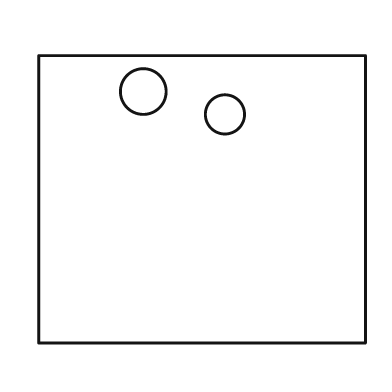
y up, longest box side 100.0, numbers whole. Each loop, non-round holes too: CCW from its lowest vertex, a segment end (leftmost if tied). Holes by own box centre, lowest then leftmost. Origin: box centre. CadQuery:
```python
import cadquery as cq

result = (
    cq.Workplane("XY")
    .moveTo(-50.0, -44.0)
    .lineTo(50.0, -44.0)
    .lineTo(50.0, 44.0)
    .lineTo(-50.0, 44.0)
    .close()
    .moveTo(7.0, 26.0)
    .circle(6.0)
    .moveTo(-18.0, 33.0)
    .circle(7.0)
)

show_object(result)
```